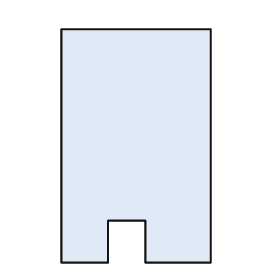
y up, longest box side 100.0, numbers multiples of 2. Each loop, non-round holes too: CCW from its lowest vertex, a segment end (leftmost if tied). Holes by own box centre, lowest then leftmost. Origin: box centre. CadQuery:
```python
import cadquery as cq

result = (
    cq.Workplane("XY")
    .moveTo(-32.0, -50.0)
    .lineTo(-12.0, -50.0)
    .lineTo(-12.0, -32.0)
    .lineTo(4.0, -32.0)
    .lineTo(4.0, -50.0)
    .lineTo(32.0, -50.0)
    .lineTo(32.0, 50.0)
    .lineTo(-32.0, 50.0)
    .close()
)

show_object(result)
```